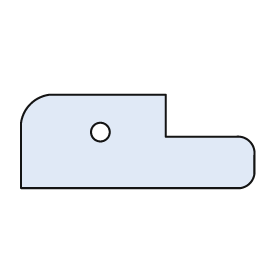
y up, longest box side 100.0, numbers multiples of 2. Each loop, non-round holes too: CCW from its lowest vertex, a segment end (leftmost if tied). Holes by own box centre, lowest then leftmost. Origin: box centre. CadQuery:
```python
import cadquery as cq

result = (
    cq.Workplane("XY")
    .moveTo(-50.0, -20.0)
    .lineTo(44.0, -20.0)
    .threePointArc((48.0, -18.0), (50.0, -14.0))
    .lineTo(50.0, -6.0)
    .threePointArc((48.0, 0.0), (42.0, 2.0))
    .lineTo(12.0, 2.0)
    .lineTo(12.0, 20.0)
    .lineTo(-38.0, 20.0)
    .threePointArc((-46.0, 16.0), (-50.0, 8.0))
    .close()
    .moveTo(-16.0, 4.0)
    .circle(4.0)
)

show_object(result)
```